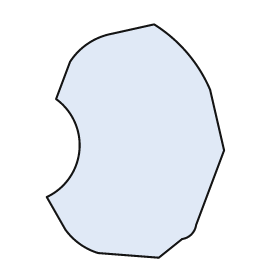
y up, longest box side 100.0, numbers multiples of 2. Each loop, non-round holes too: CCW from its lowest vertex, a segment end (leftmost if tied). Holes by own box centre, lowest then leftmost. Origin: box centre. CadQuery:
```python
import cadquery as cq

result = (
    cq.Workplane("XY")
    .moveTo(10.0, -50.0)
    .lineTo(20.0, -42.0)
    .threePointArc((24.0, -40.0), (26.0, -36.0))
    .lineTo(38.0, -4.0)
    .lineTo(32.0, 22.0)
    .threePointArc((22.0, 38.0), (8.0, 50.0))
    .lineTo(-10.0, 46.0)
    .threePointArc((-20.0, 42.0), (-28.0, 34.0))
    .lineTo(-34.0, 18.0)
    .threePointArc((-24.0, -4.0), (-38.0, -24.0))
    .lineTo(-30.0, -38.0)
    .threePointArc((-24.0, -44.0), (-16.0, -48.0))
    .close()
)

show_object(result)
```